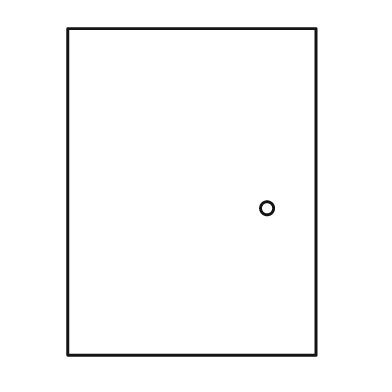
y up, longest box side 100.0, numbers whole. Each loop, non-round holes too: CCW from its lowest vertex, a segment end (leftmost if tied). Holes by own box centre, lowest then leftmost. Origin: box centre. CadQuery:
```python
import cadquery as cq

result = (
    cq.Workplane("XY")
    .moveTo(-38.0, -50.0)
    .lineTo(38.0, -50.0)
    .lineTo(38.0, 50.0)
    .lineTo(-38.0, 50.0)
    .close()
    .moveTo(23.0, -5.0)
    .circle(2.0)
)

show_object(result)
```